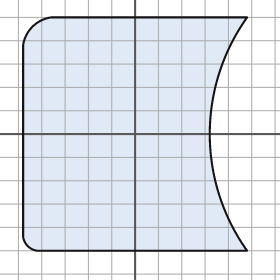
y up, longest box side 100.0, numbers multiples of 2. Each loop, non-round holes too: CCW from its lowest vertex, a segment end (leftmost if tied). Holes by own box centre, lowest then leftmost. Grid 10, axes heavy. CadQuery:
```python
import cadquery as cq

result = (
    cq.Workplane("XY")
    .moveTo(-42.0, -50.0)
    .lineTo(48.0, -50.0)
    .threePointArc((32.0, 0.0), (48.0, 50.0))
    .lineTo(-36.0, 50.0)
    .threePointArc((-44.0, 46.0), (-48.0, 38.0))
    .lineTo(-48.0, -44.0)
    .threePointArc((-46.0, -48.0), (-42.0, -50.0))
    .close()
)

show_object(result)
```